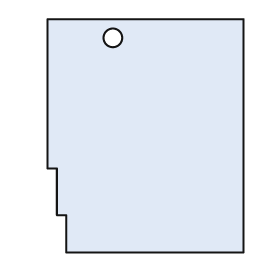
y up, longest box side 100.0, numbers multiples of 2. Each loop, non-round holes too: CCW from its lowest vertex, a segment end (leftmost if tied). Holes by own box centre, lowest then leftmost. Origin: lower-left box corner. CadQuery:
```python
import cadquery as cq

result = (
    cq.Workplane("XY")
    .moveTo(8.0, 0.0)
    .lineTo(84.0, 0.0)
    .lineTo(84.0, 100.0)
    .lineTo(0.0, 100.0)
    .lineTo(0.0, 36.0)
    .lineTo(4.0, 36.0)
    .lineTo(4.0, 16.0)
    .lineTo(8.0, 16.0)
    .close()
    .moveTo(28.0, 92.0)
    .circle(4.0)
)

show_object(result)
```